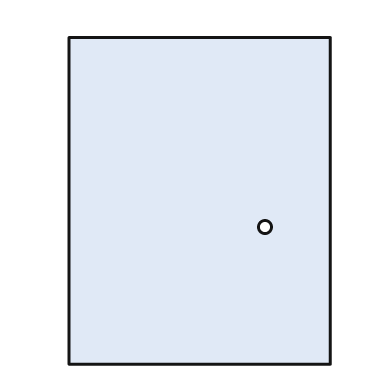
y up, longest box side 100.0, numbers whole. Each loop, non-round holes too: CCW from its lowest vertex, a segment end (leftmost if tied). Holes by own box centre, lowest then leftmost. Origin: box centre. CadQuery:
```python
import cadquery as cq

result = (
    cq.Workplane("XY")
    .moveTo(-40.0, -50.0)
    .lineTo(40.0, -50.0)
    .lineTo(40.0, 50.0)
    .lineTo(-40.0, 50.0)
    .close()
    .moveTo(20.0, -8.0)
    .circle(2.0)
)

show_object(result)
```